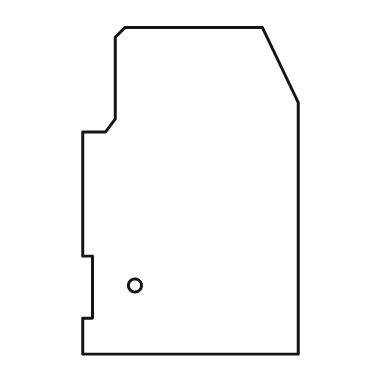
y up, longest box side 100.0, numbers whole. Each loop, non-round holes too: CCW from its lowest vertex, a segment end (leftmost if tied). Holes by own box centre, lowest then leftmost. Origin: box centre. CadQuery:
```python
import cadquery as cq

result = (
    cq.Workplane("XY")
    .moveTo(-33.0, -50.0)
    .lineTo(33.0, -50.0)
    .lineTo(33.0, 27.0)
    .lineTo(22.0, 50.0)
    .lineTo(-20.0, 50.0)
    .lineTo(-23.0, 47.0)
    .lineTo(-23.0, 22.0)
    .lineTo(-26.0, 18.0)
    .lineTo(-33.0, 18.0)
    .lineTo(-33.0, -20.0)
    .lineTo(-30.0, -20.0)
    .lineTo(-30.0, -39.0)
    .lineTo(-33.0, -39.0)
    .close()
    .moveTo(-17.0, -29.0)
    .circle(2.0)
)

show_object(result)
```